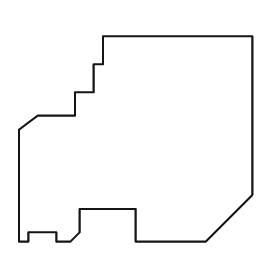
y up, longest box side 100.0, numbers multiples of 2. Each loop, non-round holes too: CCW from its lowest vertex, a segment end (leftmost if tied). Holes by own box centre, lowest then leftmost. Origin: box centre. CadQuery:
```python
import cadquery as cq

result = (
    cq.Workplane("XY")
    .moveTo(-50.0, -44.0)
    .lineTo(-46.0, -44.0)
    .lineTo(-46.0, -40.0)
    .lineTo(-34.0, -40.0)
    .lineTo(-34.0, -44.0)
    .lineTo(-28.0, -44.0)
    .lineTo(-24.0, -40.0)
    .lineTo(-24.0, -30.0)
    .lineTo(0.0, -30.0)
    .lineTo(0.0, -44.0)
    .lineTo(30.0, -44.0)
    .lineTo(50.0, -24.0)
    .lineTo(50.0, 44.0)
    .lineTo(-14.0, 44.0)
    .lineTo(-14.0, 32.0)
    .lineTo(-18.0, 32.0)
    .lineTo(-18.0, 20.0)
    .lineTo(-26.0, 20.0)
    .lineTo(-26.0, 10.0)
    .lineTo(-42.0, 10.0)
    .lineTo(-50.0, 4.0)
    .close()
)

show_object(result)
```